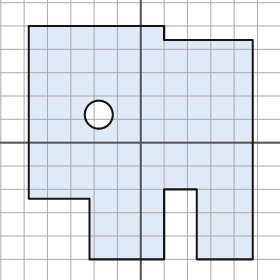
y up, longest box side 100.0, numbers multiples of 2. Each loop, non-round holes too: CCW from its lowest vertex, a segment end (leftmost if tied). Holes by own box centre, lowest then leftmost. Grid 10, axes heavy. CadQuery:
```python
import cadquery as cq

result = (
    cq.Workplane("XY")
    .moveTo(-22.0, -50.0)
    .lineTo(10.0, -50.0)
    .lineTo(10.0, -20.0)
    .lineTo(24.0, -20.0)
    .lineTo(24.0, -50.0)
    .lineTo(48.0, -50.0)
    .lineTo(48.0, 44.0)
    .lineTo(10.0, 44.0)
    .lineTo(10.0, 50.0)
    .lineTo(-48.0, 50.0)
    .lineTo(-48.0, -24.0)
    .lineTo(-22.0, -24.0)
    .close()
    .moveTo(-18.0, 12.0)
    .circle(6.0)
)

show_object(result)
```